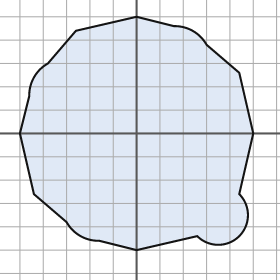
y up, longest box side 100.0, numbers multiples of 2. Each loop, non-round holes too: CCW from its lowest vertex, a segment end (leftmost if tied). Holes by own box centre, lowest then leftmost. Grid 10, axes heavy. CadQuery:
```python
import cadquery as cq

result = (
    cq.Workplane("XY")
    .moveTo(0.0, -50.0)
    .lineTo(26.0, -44.0)
    .threePointArc((44.0, -44.0), (44.0, -26.0))
    .lineTo(50.0, 0.0)
    .lineTo(44.0, 26.0)
    .lineTo(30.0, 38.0)
    .threePointArc((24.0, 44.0), (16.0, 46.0))
    .lineTo(0.0, 50.0)
    .lineTo(-26.0, 44.0)
    .lineTo(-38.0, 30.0)
    .threePointArc((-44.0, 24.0), (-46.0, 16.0))
    .lineTo(-50.0, 0.0)
    .lineTo(-44.0, -26.0)
    .lineTo(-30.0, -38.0)
    .threePointArc((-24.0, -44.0), (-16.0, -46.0))
    .close()
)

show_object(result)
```